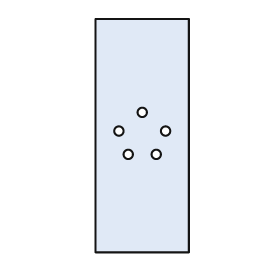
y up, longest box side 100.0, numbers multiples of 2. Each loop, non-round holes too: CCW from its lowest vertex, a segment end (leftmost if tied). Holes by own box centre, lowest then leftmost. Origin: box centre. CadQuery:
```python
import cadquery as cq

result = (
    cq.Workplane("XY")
    .moveTo(-20.0, -50.0)
    .lineTo(20.0, -50.0)
    .lineTo(20.0, 50.0)
    .lineTo(-20.0, 50.0)
    .close()
    .moveTo(-6.0, -8.0)
    .circle(2.0)
    .moveTo(6.0, -8.0)
    .circle(2.0)
    .moveTo(-10.0, 2.0)
    .circle(2.0)
    .moveTo(10.0, 2.0)
    .circle(2.0)
    .moveTo(0.0, 10.0)
    .circle(2.0)
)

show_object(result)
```